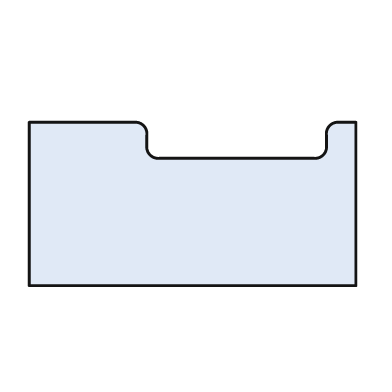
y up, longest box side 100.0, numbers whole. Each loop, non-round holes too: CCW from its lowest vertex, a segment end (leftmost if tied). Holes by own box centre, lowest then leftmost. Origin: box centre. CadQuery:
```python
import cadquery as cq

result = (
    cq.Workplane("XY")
    .moveTo(-50.0, -25.0)
    .lineTo(50.0, -25.0)
    .lineTo(50.0, 25.0)
    .lineTo(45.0, 25.0)
    .threePointArc((42.0, 24.0), (41.0, 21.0))
    .lineTo(41.0, 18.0)
    .threePointArc((40.0, 15.0), (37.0, 14.0))
    .lineTo(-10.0, 14.0)
    .threePointArc((-13.0, 15.0), (-14.0, 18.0))
    .lineTo(-14.0, 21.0)
    .threePointArc((-15.0, 24.0), (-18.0, 25.0))
    .lineTo(-50.0, 25.0)
    .close()
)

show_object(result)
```